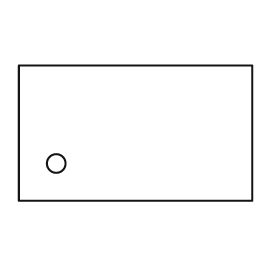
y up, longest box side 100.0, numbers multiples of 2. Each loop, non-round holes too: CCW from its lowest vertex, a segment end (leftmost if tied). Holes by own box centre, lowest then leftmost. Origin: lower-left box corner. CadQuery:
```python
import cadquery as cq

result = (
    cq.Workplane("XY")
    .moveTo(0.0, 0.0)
    .lineTo(100.0, 0.0)
    .lineTo(100.0, 58.0)
    .lineTo(0.0, 58.0)
    .close()
    .moveTo(16.0, 16.0)
    .circle(4.0)
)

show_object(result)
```